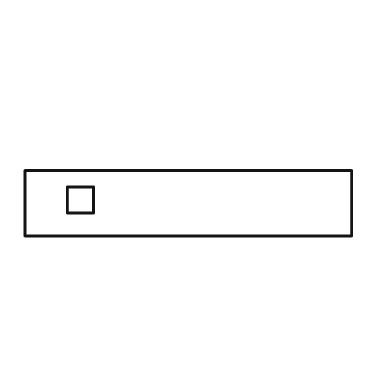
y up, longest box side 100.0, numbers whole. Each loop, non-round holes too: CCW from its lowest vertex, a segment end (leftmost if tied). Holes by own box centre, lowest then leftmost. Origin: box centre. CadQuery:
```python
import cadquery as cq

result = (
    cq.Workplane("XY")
    .moveTo(-50.0, -10.0)
    .lineTo(50.0, -10.0)
    .lineTo(50.0, 10.0)
    .lineTo(-50.0, 10.0)
    .close()
    .moveTo(-37.0, -3.0)
    .lineTo(-29.0, -3.0)
    .lineTo(-29.0, 5.0)
    .lineTo(-37.0, 5.0)
    .close()
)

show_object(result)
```